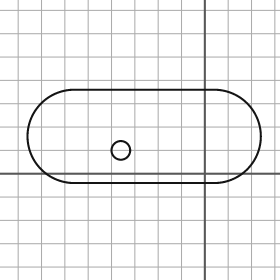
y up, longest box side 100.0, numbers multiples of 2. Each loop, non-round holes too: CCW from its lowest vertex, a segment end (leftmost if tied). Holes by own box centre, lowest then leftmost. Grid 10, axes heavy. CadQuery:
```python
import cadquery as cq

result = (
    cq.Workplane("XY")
    .moveTo(-56.0, -4.0)
    .lineTo(4.0, -4.0)
    .threePointArc((24.0, 16.0), (4.0, 36.0))
    .lineTo(-56.0, 36.0)
    .threePointArc((-76.0, 16.0), (-56.0, -4.0))
    .close()
    .moveTo(-36.0, 10.0)
    .circle(4.0)
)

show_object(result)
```